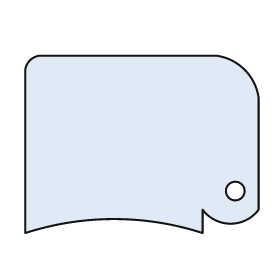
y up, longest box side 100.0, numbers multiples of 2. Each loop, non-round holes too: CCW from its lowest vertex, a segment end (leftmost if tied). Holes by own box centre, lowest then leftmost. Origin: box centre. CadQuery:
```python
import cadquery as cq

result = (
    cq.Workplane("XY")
    .moveTo(-50.0, -38.0)
    .threePointArc((-12.0, -32.0), (26.0, -38.0))
    .lineTo(26.0, -28.0)
    .threePointArc((38.0, -34.0), (50.0, -28.0))
    .lineTo(50.0, 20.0)
    .threePointArc((44.0, 32.0), (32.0, 38.0))
    .lineTo(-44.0, 38.0)
    .threePointArc((-48.0, 36.0), (-50.0, 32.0))
    .close()
    .moveTo(40.0, -20.0)
    .circle(4.0)
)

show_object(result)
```